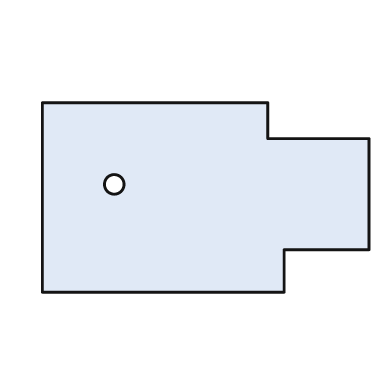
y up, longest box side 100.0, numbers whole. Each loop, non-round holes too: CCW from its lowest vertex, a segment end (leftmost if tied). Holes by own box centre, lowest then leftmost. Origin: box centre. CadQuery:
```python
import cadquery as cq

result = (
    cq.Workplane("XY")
    .moveTo(-50.0, -29.0)
    .lineTo(24.0, -29.0)
    .lineTo(24.0, -16.0)
    .lineTo(50.0, -16.0)
    .lineTo(50.0, 18.0)
    .lineTo(19.0, 18.0)
    .lineTo(19.0, 29.0)
    .lineTo(-50.0, 29.0)
    .close()
    .moveTo(-28.0, 4.0)
    .circle(3.0)
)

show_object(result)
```